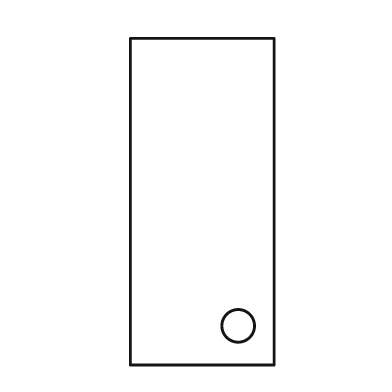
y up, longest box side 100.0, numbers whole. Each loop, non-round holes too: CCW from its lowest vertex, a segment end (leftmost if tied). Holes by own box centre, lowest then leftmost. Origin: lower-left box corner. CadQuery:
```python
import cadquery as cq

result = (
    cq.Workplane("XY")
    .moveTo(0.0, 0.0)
    .lineTo(44.0, 0.0)
    .lineTo(44.0, 100.0)
    .lineTo(0.0, 100.0)
    .close()
    .moveTo(33.0, 12.0)
    .circle(5.0)
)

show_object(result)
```